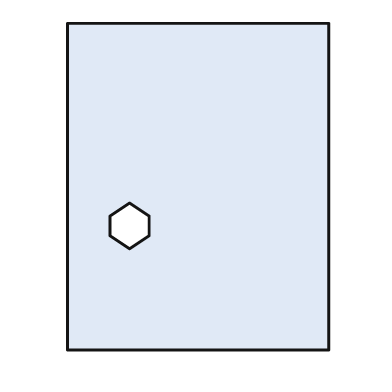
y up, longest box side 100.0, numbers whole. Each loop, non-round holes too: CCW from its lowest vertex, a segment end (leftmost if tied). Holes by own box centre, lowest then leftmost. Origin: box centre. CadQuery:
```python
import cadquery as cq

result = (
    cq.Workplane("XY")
    .moveTo(-40.0, -50.0)
    .lineTo(40.0, -50.0)
    .lineTo(40.0, 50.0)
    .lineTo(-40.0, 50.0)
    .close()
    .moveTo(-21.0, -19.0)
    .lineTo(-15.0, -15.0)
    .lineTo(-15.0, -9.0)
    .lineTo(-21.0, -5.0)
    .lineTo(-27.0, -9.0)
    .lineTo(-27.0, -15.0)
    .close()
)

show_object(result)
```